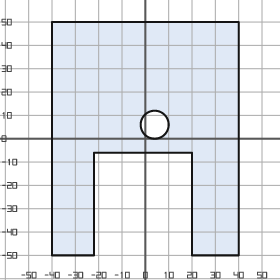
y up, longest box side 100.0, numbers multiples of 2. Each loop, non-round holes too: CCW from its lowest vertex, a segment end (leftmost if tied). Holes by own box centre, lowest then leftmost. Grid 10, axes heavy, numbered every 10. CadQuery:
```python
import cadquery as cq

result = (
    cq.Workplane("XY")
    .moveTo(-40.0, -50.0)
    .lineTo(-22.0, -50.0)
    .lineTo(-22.0, -6.0)
    .lineTo(20.0, -6.0)
    .lineTo(20.0, -50.0)
    .lineTo(40.0, -50.0)
    .lineTo(40.0, 50.0)
    .lineTo(-40.0, 50.0)
    .close()
    .moveTo(4.0, 6.0)
    .circle(6.0)
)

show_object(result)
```